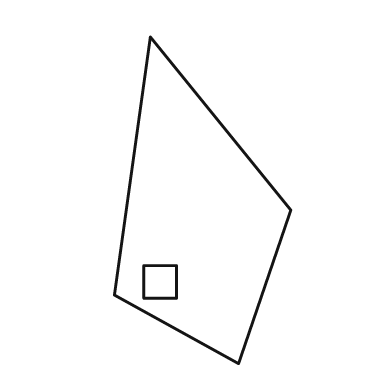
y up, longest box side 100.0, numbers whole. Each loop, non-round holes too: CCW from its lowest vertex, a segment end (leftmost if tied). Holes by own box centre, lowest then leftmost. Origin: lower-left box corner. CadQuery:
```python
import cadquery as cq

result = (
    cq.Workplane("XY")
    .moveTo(38.0, 0.0)
    .lineTo(54.0, 47.0)
    .lineTo(11.0, 100.0)
    .lineTo(0.0, 21.0)
    .close()
    .moveTo(9.0, 20.0)
    .lineTo(19.0, 20.0)
    .lineTo(19.0, 30.0)
    .lineTo(9.0, 30.0)
    .close()
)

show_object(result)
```